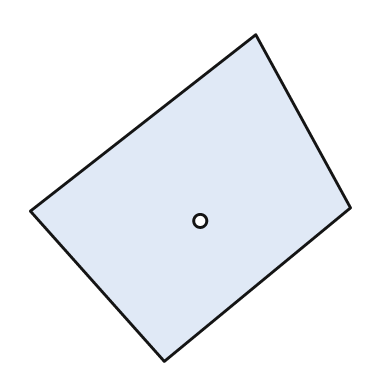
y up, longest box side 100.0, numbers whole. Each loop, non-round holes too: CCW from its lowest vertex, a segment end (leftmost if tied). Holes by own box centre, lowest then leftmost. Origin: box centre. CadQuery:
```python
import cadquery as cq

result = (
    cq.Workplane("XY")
    .moveTo(-8.0, -50.0)
    .lineTo(49.0, -3.0)
    .lineTo(20.0, 50.0)
    .lineTo(-49.0, -4.0)
    .close()
    .moveTo(3.0, -7.0)
    .circle(2.0)
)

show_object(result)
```